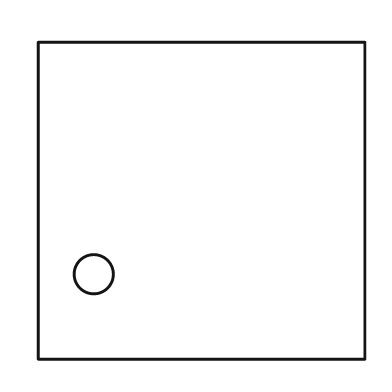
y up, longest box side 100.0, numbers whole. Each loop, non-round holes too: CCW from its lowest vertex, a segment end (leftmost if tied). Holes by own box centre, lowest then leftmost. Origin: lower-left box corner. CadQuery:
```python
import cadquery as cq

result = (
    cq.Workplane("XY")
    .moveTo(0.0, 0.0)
    .lineTo(100.0, 0.0)
    .lineTo(100.0, 97.0)
    .lineTo(0.0, 97.0)
    .close()
    .moveTo(17.0, 26.0)
    .circle(6.0)
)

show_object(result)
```